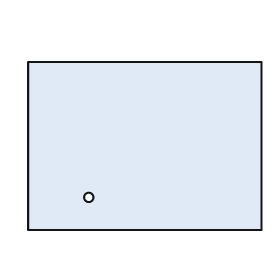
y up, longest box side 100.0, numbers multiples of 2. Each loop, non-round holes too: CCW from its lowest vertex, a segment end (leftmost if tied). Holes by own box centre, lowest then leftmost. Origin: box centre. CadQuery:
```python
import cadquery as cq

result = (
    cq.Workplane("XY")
    .moveTo(-50.0, -36.0)
    .lineTo(50.0, -36.0)
    .lineTo(50.0, 36.0)
    .lineTo(-50.0, 36.0)
    .close()
    .moveTo(-24.0, -22.0)
    .circle(2.0)
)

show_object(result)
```